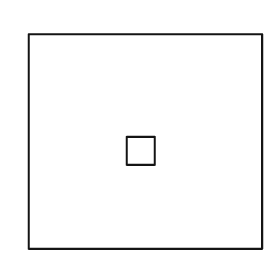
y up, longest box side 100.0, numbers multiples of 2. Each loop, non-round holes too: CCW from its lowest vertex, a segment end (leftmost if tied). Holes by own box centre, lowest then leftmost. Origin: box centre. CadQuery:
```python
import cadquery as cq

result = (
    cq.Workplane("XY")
    .moveTo(-50.0, -46.0)
    .lineTo(50.0, -46.0)
    .lineTo(50.0, 46.0)
    .lineTo(-50.0, 46.0)
    .close()
    .moveTo(-8.0, -10.0)
    .lineTo(4.0, -10.0)
    .lineTo(4.0, 2.0)
    .lineTo(-8.0, 2.0)
    .close()
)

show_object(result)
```